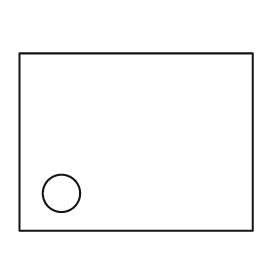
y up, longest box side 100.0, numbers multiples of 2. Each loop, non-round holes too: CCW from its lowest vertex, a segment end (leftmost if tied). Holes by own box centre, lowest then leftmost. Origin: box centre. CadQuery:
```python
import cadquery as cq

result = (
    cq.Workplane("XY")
    .moveTo(-50.0, -38.0)
    .lineTo(50.0, -38.0)
    .lineTo(50.0, 38.0)
    .lineTo(-50.0, 38.0)
    .close()
    .moveTo(-32.0, -22.0)
    .circle(8.0)
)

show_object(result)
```